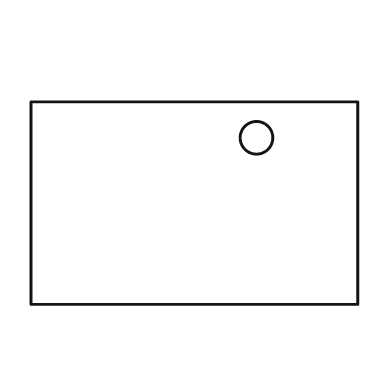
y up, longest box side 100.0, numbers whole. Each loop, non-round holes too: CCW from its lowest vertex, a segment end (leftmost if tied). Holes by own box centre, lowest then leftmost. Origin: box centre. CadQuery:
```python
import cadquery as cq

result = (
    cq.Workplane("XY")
    .moveTo(-50.0, -31.0)
    .lineTo(50.0, -31.0)
    .lineTo(50.0, 31.0)
    .lineTo(-50.0, 31.0)
    .close()
    .moveTo(19.0, 20.0)
    .circle(5.0)
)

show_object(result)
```